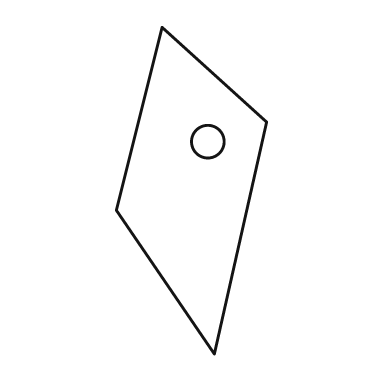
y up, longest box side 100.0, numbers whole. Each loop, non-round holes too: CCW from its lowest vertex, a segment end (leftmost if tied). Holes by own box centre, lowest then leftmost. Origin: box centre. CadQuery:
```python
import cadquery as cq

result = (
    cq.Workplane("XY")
    .moveTo(7.0, -50.0)
    .lineTo(23.0, 21.0)
    .lineTo(-9.0, 50.0)
    .lineTo(-23.0, -6.0)
    .close()
    .moveTo(5.0, 15.0)
    .circle(5.0)
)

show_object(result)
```